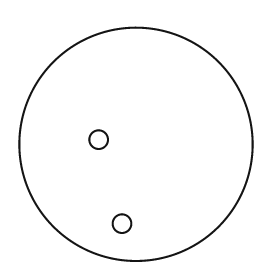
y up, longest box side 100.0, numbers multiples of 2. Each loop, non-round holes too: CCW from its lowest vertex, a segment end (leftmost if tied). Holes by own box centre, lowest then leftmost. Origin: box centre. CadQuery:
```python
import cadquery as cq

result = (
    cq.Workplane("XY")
    .moveTo(0.0, 0.0)
    .circle(50.0)
    .moveTo(-6.0, -34.0)
    .circle(4.0)
    .moveTo(-16.0, 2.0)
    .circle(4.0)
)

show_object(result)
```